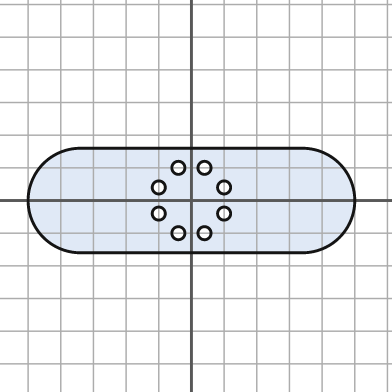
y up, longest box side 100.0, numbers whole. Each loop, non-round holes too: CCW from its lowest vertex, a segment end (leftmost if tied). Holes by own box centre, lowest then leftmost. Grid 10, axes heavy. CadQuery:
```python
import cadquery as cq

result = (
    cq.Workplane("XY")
    .moveTo(-34.0, -16.0)
    .lineTo(34.0, -16.0)
    .threePointArc((50.0, 0.0), (34.0, 16.0))
    .lineTo(-34.0, 16.0)
    .threePointArc((-50.0, 0.0), (-34.0, -16.0))
    .close()
    .moveTo(-4.0, -10.0)
    .circle(2.0)
    .moveTo(4.0, -10.0)
    .circle(2.0)
    .moveTo(-10.0, -4.0)
    .circle(2.0)
    .moveTo(10.0, -4.0)
    .circle(2.0)
    .moveTo(-10.0, 4.0)
    .circle(2.0)
    .moveTo(10.0, 4.0)
    .circle(2.0)
    .moveTo(-4.0, 10.0)
    .circle(2.0)
    .moveTo(4.0, 10.0)
    .circle(2.0)
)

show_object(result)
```